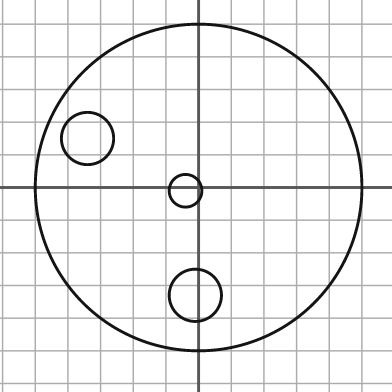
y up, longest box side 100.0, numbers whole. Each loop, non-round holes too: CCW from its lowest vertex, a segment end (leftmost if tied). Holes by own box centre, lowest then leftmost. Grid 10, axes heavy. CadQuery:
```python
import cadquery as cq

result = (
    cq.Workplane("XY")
    .moveTo(0.0, 0.0)
    .circle(50.0)
    .moveTo(-1.0, -33.0)
    .circle(8.0)
    .moveTo(-4.0, -1.0)
    .circle(5.0)
    .moveTo(-34.0, 15.0)
    .circle(8.0)
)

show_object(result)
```